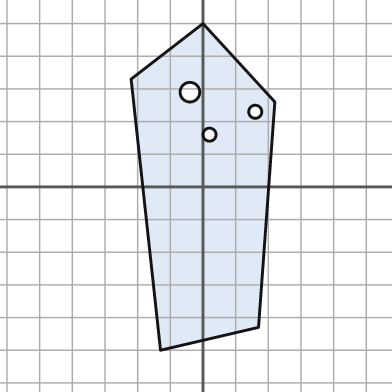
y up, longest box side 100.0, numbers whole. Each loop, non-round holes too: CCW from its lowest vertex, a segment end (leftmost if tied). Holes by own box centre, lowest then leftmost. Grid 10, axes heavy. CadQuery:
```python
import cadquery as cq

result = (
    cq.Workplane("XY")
    .moveTo(-13.0, -50.0)
    .lineTo(17.0, -43.0)
    .lineTo(22.0, 26.0)
    .lineTo(0.0, 50.0)
    .lineTo(-22.0, 33.0)
    .close()
    .moveTo(2.0, 16.0)
    .circle(2.0)
    .moveTo(16.0, 23.0)
    .circle(2.0)
    .moveTo(-4.0, 29.0)
    .circle(3.0)
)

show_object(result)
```